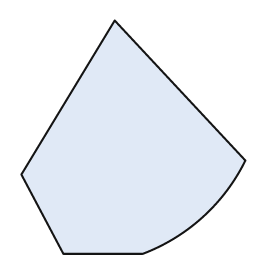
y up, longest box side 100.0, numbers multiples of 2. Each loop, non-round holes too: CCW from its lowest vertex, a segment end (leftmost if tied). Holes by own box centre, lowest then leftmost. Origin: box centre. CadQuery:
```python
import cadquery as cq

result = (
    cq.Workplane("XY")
    .moveTo(-30.0, -50.0)
    .lineTo(4.0, -50.0)
    .threePointArc((30.0, -34.0), (48.0, -10.0))
    .lineTo(-8.0, 50.0)
    .lineTo(-48.0, -16.0)
    .close()
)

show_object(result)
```